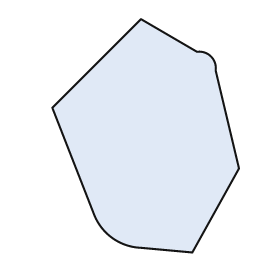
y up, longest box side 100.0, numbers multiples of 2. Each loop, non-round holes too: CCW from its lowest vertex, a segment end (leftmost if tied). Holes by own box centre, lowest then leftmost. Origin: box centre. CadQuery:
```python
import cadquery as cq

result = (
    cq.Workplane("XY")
    .moveTo(20.0, -50.0)
    .lineTo(40.0, -14.0)
    .lineTo(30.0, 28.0)
    .threePointArc((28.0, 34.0), (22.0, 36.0))
    .lineTo(-2.0, 50.0)
    .lineTo(-40.0, 12.0)
    .lineTo(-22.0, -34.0)
    .threePointArc((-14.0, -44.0), (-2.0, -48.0))
    .close()
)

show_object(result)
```